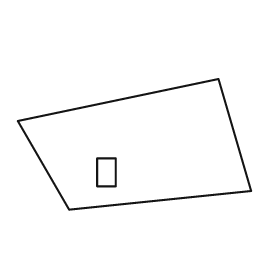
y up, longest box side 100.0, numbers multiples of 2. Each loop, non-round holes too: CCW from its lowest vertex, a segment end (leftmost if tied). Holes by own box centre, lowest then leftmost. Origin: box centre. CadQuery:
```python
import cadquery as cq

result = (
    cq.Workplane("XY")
    .moveTo(-28.0, -28.0)
    .lineTo(50.0, -20.0)
    .lineTo(36.0, 28.0)
    .lineTo(-50.0, 10.0)
    .close()
    .moveTo(-16.0, -18.0)
    .lineTo(-8.0, -18.0)
    .lineTo(-8.0, -6.0)
    .lineTo(-16.0, -6.0)
    .close()
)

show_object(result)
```